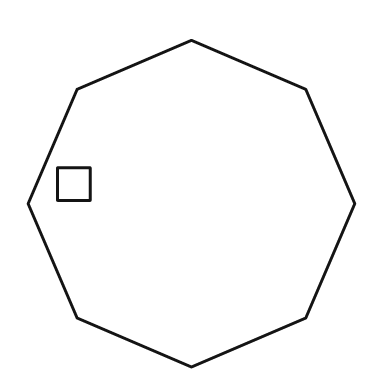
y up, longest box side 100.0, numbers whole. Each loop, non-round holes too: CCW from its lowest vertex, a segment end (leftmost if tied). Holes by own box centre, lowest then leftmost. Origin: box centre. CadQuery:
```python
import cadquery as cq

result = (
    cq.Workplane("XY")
    .moveTo(0.0, -50.0)
    .lineTo(35.0, -35.0)
    .lineTo(50.0, 0.0)
    .lineTo(35.0, 35.0)
    .lineTo(0.0, 50.0)
    .lineTo(-35.0, 35.0)
    .lineTo(-50.0, 0.0)
    .lineTo(-35.0, -35.0)
    .close()
    .moveTo(-41.0, 1.0)
    .lineTo(-31.0, 1.0)
    .lineTo(-31.0, 11.0)
    .lineTo(-41.0, 11.0)
    .close()
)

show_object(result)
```